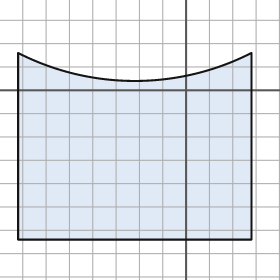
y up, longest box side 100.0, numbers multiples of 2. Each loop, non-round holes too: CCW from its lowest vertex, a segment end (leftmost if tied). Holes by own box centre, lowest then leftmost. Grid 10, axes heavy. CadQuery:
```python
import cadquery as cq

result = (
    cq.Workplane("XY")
    .moveTo(-72.0, -64.0)
    .lineTo(28.0, -64.0)
    .lineTo(28.0, 16.0)
    .threePointArc((-22.0, 4.0), (-72.0, 16.0))
    .close()
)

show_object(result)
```